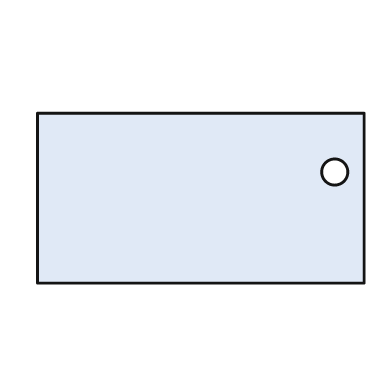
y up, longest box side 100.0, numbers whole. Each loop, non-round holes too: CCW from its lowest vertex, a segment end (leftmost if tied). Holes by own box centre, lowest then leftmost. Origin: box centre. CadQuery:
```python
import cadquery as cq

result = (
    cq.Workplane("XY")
    .moveTo(-50.0, -26.0)
    .lineTo(50.0, -26.0)
    .lineTo(50.0, 26.0)
    .lineTo(-50.0, 26.0)
    .close()
    .moveTo(41.0, 8.0)
    .circle(4.0)
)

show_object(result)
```